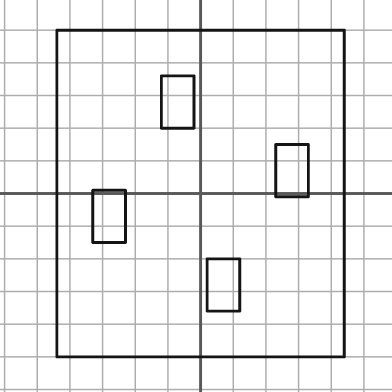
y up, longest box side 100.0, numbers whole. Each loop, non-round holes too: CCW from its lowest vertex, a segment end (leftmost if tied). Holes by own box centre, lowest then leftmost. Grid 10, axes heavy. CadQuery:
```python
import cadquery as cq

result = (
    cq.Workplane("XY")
    .moveTo(-44.0, -50.0)
    .lineTo(44.0, -50.0)
    .lineTo(44.0, 50.0)
    .lineTo(-44.0, 50.0)
    .close()
    .moveTo(2.0, -36.0)
    .lineTo(12.0, -36.0)
    .lineTo(12.0, -20.0)
    .lineTo(2.0, -20.0)
    .close()
    .moveTo(-33.0, -15.0)
    .lineTo(-23.0, -15.0)
    .lineTo(-23.0, 1.0)
    .lineTo(-33.0, 1.0)
    .close()
    .moveTo(23.0, -1.0)
    .lineTo(33.0, -1.0)
    .lineTo(33.0, 15.0)
    .lineTo(23.0, 15.0)
    .close()
    .moveTo(-12.0, 20.0)
    .lineTo(-2.0, 20.0)
    .lineTo(-2.0, 36.0)
    .lineTo(-12.0, 36.0)
    .close()
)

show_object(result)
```